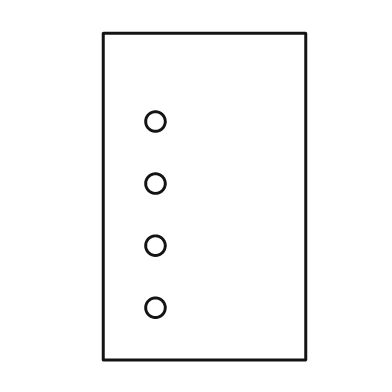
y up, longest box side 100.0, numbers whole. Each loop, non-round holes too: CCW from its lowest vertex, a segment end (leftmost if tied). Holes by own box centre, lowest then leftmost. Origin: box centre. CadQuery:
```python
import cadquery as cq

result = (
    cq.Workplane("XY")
    .moveTo(-31.0, -50.0)
    .lineTo(31.0, -50.0)
    .lineTo(31.0, 50.0)
    .lineTo(-31.0, 50.0)
    .close()
    .moveTo(-15.0, -34.0)
    .circle(3.0)
    .moveTo(-15.0, -15.0)
    .circle(3.0)
    .moveTo(-15.0, 4.0)
    .circle(3.0)
    .moveTo(-15.0, 23.0)
    .circle(3.0)
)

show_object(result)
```